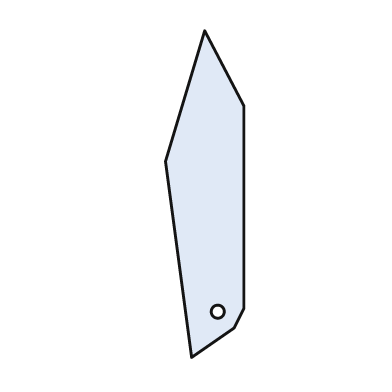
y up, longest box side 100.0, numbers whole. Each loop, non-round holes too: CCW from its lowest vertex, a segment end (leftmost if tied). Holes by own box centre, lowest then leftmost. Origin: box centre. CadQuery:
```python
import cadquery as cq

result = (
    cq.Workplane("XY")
    .moveTo(-4.0, -50.0)
    .lineTo(9.0, -41.0)
    .lineTo(12.0, -35.0)
    .lineTo(12.0, 27.0)
    .lineTo(0.0, 50.0)
    .lineTo(-12.0, 10.0)
    .close()
    .moveTo(4.0, -36.0)
    .circle(2.0)
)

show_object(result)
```